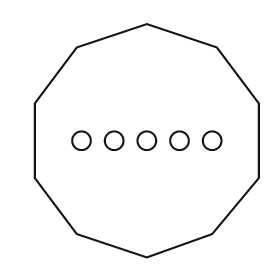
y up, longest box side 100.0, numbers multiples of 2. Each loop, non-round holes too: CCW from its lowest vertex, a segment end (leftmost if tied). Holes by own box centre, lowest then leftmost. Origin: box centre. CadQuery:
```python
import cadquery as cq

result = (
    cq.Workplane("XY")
    .moveTo(0.0, -50.0)
    .lineTo(28.0, -40.0)
    .lineTo(48.0, -16.0)
    .lineTo(48.0, 16.0)
    .lineTo(30.0, 40.0)
    .lineTo(0.0, 50.0)
    .lineTo(-30.0, 40.0)
    .lineTo(-48.0, 16.0)
    .lineTo(-48.0, -16.0)
    .lineTo(-30.0, -40.0)
    .close()
    .moveTo(-28.0, 0.0)
    .circle(4.0)
    .moveTo(-14.0, 0.0)
    .circle(4.0)
    .moveTo(0.0, 0.0)
    .circle(4.0)
    .moveTo(14.0, 0.0)
    .circle(4.0)
    .moveTo(28.0, 0.0)
    .circle(4.0)
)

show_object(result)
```